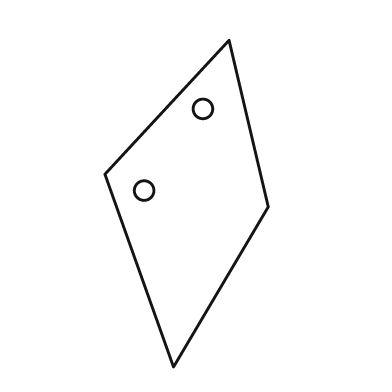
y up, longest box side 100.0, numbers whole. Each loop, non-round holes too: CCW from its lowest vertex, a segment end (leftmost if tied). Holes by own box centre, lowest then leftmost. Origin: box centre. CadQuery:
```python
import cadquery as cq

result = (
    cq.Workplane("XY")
    .moveTo(-4.0, -50.0)
    .lineTo(25.0, -1.0)
    .lineTo(13.0, 50.0)
    .lineTo(-25.0, 9.0)
    .close()
    .moveTo(-13.0, 4.0)
    .circle(3.0)
    .moveTo(5.0, 29.0)
    .circle(3.0)
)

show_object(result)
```